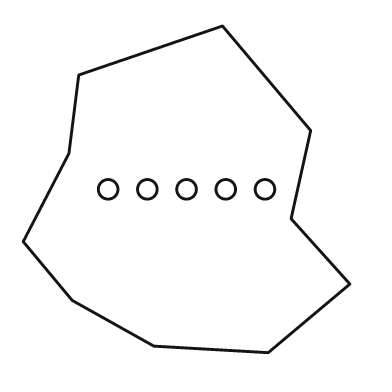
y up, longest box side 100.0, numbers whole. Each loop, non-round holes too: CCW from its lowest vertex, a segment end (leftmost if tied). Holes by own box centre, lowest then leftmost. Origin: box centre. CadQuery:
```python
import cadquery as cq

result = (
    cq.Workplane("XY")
    .moveTo(25.0, -50.0)
    .lineTo(50.0, -29.0)
    .lineTo(32.0, -9.0)
    .lineTo(38.0, 18.0)
    .lineTo(11.0, 50.0)
    .lineTo(-33.0, 35.0)
    .lineTo(-36.0, 11.0)
    .lineTo(-50.0, -16.0)
    .lineTo(-35.0, -34.0)
    .lineTo(-10.0, -48.0)
    .close()
    .moveTo(-24.0, 0.0)
    .circle(3.0)
    .moveTo(-12.0, 0.0)
    .circle(3.0)
    .moveTo(0.0, 0.0)
    .circle(3.0)
    .moveTo(12.0, 0.0)
    .circle(3.0)
    .moveTo(24.0, 0.0)
    .circle(3.0)
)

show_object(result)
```